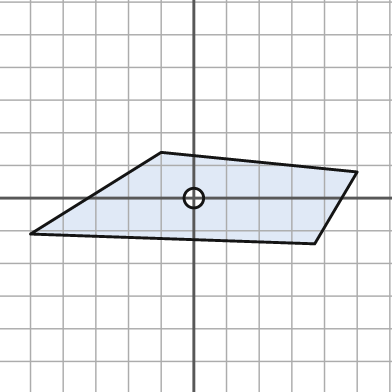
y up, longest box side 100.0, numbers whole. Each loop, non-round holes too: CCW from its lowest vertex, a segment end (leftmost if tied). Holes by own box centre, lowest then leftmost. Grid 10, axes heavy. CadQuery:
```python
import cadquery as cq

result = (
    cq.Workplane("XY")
    .moveTo(37.0, -14.0)
    .lineTo(50.0, 8.0)
    .lineTo(-10.0, 14.0)
    .lineTo(-50.0, -11.0)
    .close()
    .moveTo(0.0, 0.0)
    .circle(3.0)
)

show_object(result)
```